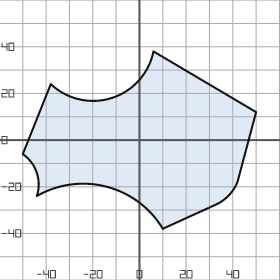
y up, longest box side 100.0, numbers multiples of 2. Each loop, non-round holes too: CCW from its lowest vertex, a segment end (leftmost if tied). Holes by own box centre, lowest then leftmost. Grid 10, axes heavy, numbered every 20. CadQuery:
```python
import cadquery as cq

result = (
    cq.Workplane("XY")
    .moveTo(10.0, -38.0)
    .lineTo(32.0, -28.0)
    .threePointArc((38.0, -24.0), (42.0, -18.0))
    .lineTo(50.0, 12.0)
    .lineTo(6.0, 38.0)
    .threePointArc((-12.0, 18.0), (-38.0, 24.0))
    .lineTo(-50.0, -6.0)
    .threePointArc((-44.0, -14.0), (-44.0, -24.0))
    .threePointArc((-14.0, -20.0), (10.0, -38.0))
    .close()
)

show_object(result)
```